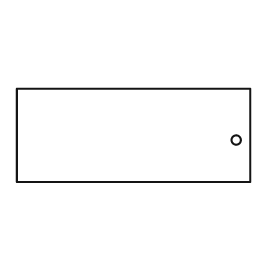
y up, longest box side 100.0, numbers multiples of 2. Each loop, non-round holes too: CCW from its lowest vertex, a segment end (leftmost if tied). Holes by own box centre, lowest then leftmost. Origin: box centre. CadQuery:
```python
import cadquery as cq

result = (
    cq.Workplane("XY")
    .moveTo(-50.0, -20.0)
    .lineTo(50.0, -20.0)
    .lineTo(50.0, 20.0)
    .lineTo(-50.0, 20.0)
    .close()
    .moveTo(44.0, -2.0)
    .circle(2.0)
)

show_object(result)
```